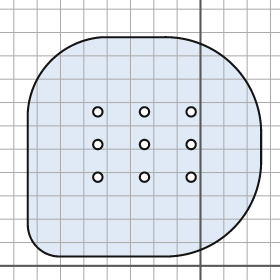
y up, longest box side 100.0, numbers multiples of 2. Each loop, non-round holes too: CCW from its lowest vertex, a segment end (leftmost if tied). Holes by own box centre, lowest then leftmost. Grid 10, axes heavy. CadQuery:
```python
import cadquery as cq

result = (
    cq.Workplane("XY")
    .moveTo(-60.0, 4.0)
    .lineTo(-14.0, 4.0)
    .threePointArc((14.0, 16.0), (26.0, 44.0))
    .lineTo(26.0, 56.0)
    .threePointArc((14.0, 86.0), (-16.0, 98.0))
    .lineTo(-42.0, 98.0)
    .threePointArc((-64.0, 88.0), (-74.0, 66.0))
    .lineTo(-74.0, 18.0)
    .threePointArc((-70.0, 8.0), (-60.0, 4.0))
    .close()
    .moveTo(-44.0, 38.0)
    .circle(2.0)
    .moveTo(-24.0, 38.0)
    .circle(2.0)
    .moveTo(-4.0, 38.0)
    .circle(2.0)
    .moveTo(-44.0, 52.0)
    .circle(2.0)
    .moveTo(-24.0, 52.0)
    .circle(2.0)
    .moveTo(-4.0, 52.0)
    .circle(2.0)
    .moveTo(-44.0, 66.0)
    .circle(2.0)
    .moveTo(-24.0, 66.0)
    .circle(2.0)
    .moveTo(-4.0, 66.0)
    .circle(2.0)
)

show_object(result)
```